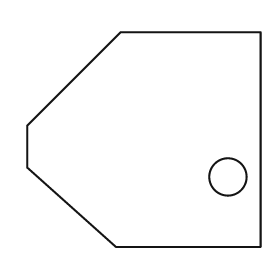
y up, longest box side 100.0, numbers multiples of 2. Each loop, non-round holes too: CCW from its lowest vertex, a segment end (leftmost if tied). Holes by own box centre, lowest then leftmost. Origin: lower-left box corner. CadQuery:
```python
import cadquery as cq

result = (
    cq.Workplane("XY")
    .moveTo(38.0, 0.0)
    .lineTo(100.0, 0.0)
    .lineTo(100.0, 92.0)
    .lineTo(40.0, 92.0)
    .lineTo(0.0, 52.0)
    .lineTo(0.0, 34.0)
    .close()
    .moveTo(86.0, 30.0)
    .circle(8.0)
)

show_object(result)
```